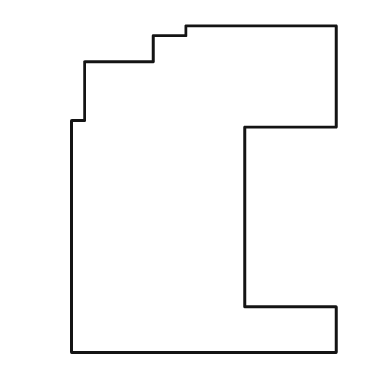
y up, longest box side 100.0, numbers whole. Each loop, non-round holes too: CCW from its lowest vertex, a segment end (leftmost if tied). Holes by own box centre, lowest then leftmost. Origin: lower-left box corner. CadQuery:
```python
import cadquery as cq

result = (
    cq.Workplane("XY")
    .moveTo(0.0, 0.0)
    .lineTo(81.0, 0.0)
    .lineTo(81.0, 14.0)
    .lineTo(53.0, 14.0)
    .lineTo(53.0, 69.0)
    .lineTo(81.0, 69.0)
    .lineTo(81.0, 100.0)
    .lineTo(35.0, 100.0)
    .lineTo(35.0, 97.0)
    .lineTo(25.0, 97.0)
    .lineTo(25.0, 89.0)
    .lineTo(4.0, 89.0)
    .lineTo(4.0, 71.0)
    .lineTo(0.0, 71.0)
    .close()
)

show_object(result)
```